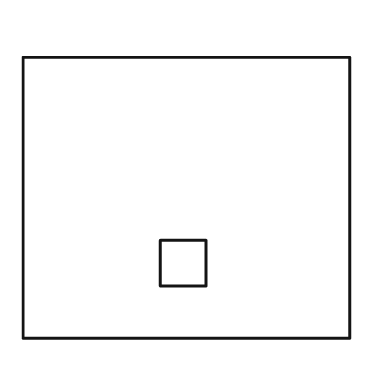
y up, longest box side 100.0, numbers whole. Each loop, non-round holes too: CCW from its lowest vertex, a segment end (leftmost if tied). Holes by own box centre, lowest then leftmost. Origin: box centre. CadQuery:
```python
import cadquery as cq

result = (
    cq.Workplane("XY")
    .moveTo(-50.0, -43.0)
    .lineTo(50.0, -43.0)
    .lineTo(50.0, 43.0)
    .lineTo(-50.0, 43.0)
    .close()
    .moveTo(-8.0, -27.0)
    .lineTo(6.0, -27.0)
    .lineTo(6.0, -13.0)
    .lineTo(-8.0, -13.0)
    .close()
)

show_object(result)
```